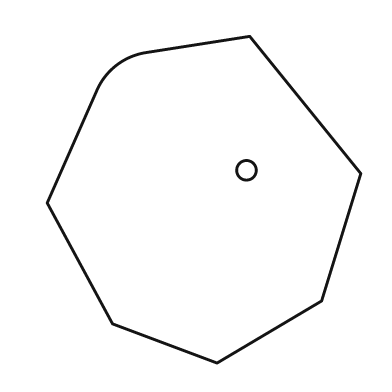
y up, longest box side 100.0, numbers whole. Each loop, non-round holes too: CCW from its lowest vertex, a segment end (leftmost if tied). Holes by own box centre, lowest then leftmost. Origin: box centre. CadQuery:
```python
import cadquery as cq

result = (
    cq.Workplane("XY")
    .moveTo(4.0, -50.0)
    .lineTo(36.0, -31.0)
    .lineTo(48.0, 8.0)
    .lineTo(14.0, 50.0)
    .lineTo(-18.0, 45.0)
    .threePointArc((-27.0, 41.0), (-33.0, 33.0))
    .lineTo(-48.0, -1.0)
    .lineTo(-28.0, -38.0)
    .close()
    .moveTo(13.0, 9.0)
    .circle(3.0)
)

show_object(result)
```